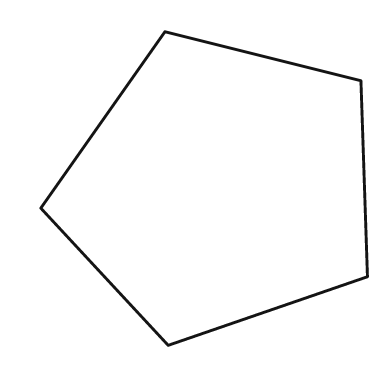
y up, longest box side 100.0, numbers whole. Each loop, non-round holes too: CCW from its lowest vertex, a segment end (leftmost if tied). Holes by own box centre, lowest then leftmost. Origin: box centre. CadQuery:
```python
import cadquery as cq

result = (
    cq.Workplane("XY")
    .moveTo(-11.0, -48.0)
    .lineTo(50.0, -27.0)
    .lineTo(48.0, 33.0)
    .lineTo(-12.0, 48.0)
    .lineTo(-50.0, -6.0)
    .close()
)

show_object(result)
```